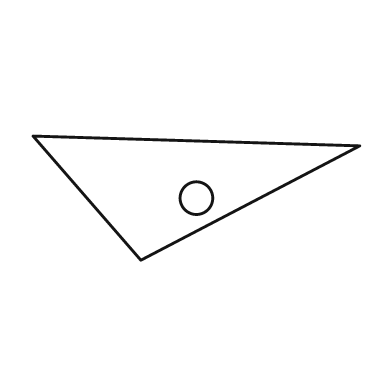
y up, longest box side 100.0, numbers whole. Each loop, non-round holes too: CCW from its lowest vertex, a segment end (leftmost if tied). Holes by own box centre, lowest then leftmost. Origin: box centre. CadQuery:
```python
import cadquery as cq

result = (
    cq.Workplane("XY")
    .moveTo(-17.0, -19.0)
    .lineTo(50.0, 16.0)
    .lineTo(-50.0, 19.0)
    .close()
    .moveTo(0.0, 0.0)
    .circle(5.0)
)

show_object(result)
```